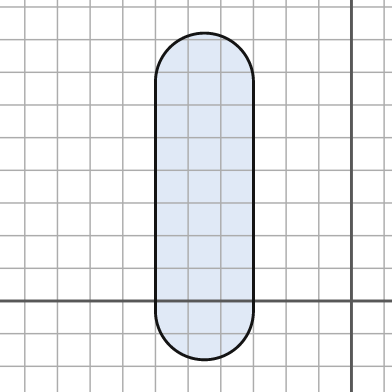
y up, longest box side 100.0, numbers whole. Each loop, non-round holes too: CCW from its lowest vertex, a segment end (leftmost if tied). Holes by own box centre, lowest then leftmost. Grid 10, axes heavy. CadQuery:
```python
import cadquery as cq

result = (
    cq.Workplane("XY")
    .moveTo(-60.0, -3.0)
    .threePointArc((-45.0, -18.0), (-30.0, -3.0))
    .lineTo(-30.0, 67.0)
    .threePointArc((-45.0, 82.0), (-60.0, 67.0))
    .close()
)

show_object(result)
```